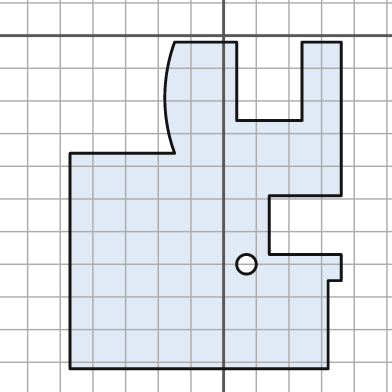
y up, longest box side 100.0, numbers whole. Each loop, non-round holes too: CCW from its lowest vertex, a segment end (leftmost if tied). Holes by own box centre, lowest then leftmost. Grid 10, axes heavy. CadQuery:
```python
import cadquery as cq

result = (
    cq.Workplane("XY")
    .moveTo(-47.0, -102.0)
    .lineTo(32.0, -102.0)
    .lineTo(32.0, -75.0)
    .lineTo(36.0, -75.0)
    .lineTo(36.0, -67.0)
    .lineTo(14.0, -67.0)
    .lineTo(14.0, -49.0)
    .lineTo(36.0, -49.0)
    .lineTo(36.0, -2.0)
    .lineTo(24.0, -2.0)
    .lineTo(24.0, -26.0)
    .lineTo(4.0, -26.0)
    .lineTo(4.0, -2.0)
    .lineTo(-15.0, -2.0)
    .threePointArc((-18.0, -19.0), (-15.0, -36.0))
    .lineTo(-47.0, -36.0)
    .close()
    .moveTo(7.0, -70.0)
    .circle(3.0)
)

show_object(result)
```